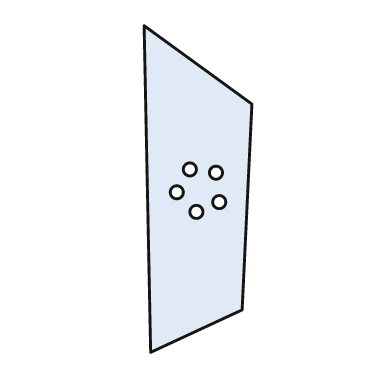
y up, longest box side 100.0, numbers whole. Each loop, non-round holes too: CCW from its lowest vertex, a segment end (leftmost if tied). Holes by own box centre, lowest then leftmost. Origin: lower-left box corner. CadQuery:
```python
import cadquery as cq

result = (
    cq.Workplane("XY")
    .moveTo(2.0, 0.0)
    .lineTo(30.0, 13.0)
    .lineTo(33.0, 76.0)
    .lineTo(0.0, 100.0)
    .close()
    .moveTo(16.0, 43.0)
    .circle(2.0)
    .moveTo(23.0, 46.0)
    .circle(2.0)
    .moveTo(10.0, 49.0)
    .circle(2.0)
    .moveTo(22.0, 55.0)
    .circle(2.0)
    .moveTo(14.0, 56.0)
    .circle(2.0)
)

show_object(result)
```